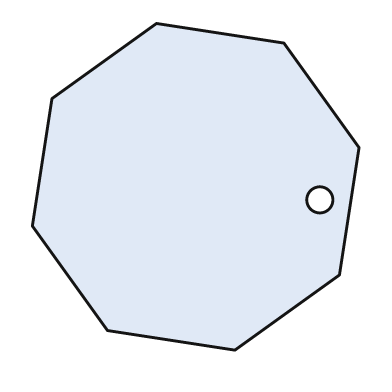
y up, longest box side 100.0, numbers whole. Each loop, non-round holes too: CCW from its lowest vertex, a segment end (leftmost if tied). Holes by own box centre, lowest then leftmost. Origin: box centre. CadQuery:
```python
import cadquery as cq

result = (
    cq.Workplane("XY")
    .moveTo(12.0, -50.0)
    .lineTo(44.0, -27.0)
    .lineTo(50.0, 12.0)
    .lineTo(27.0, 44.0)
    .lineTo(-12.0, 50.0)
    .lineTo(-44.0, 27.0)
    .lineTo(-50.0, -12.0)
    .lineTo(-27.0, -44.0)
    .close()
    .moveTo(38.0, -4.0)
    .circle(4.0)
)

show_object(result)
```